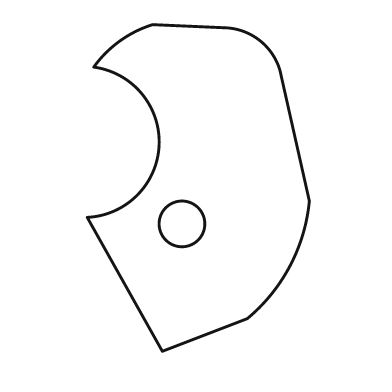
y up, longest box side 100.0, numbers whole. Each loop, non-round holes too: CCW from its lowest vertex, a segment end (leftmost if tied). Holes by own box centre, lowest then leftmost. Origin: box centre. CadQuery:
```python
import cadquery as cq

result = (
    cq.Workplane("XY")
    .moveTo(-11.0, -50.0)
    .lineTo(15.0, -40.0)
    .threePointArc((28.0, -24.0), (34.0, -4.0))
    .lineTo(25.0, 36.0)
    .threePointArc((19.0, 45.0), (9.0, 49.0))
    .lineTo(-14.0, 50.0)
    .threePointArc((-24.0, 45.0), (-32.0, 37.0))
    .threePointArc((-12.0, 13.0), (-34.0, -9.0))
    .close()
    .moveTo(-5.0, -11.0)
    .circle(7.0)
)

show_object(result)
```